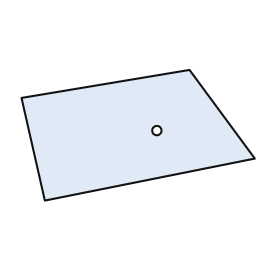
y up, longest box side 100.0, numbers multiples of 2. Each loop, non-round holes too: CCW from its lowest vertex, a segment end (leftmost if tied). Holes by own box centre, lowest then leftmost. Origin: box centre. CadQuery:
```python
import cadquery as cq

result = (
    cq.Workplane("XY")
    .moveTo(-40.0, -28.0)
    .lineTo(50.0, -10.0)
    .lineTo(22.0, 28.0)
    .lineTo(-50.0, 16.0)
    .close()
    .moveTo(8.0, 2.0)
    .circle(2.0)
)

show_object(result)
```